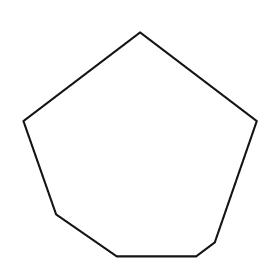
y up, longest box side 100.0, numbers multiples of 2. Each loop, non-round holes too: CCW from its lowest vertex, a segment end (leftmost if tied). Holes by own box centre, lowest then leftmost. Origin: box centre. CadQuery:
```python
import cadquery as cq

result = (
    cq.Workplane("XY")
    .moveTo(-10.0, -48.0)
    .lineTo(24.0, -48.0)
    .lineTo(32.0, -42.0)
    .lineTo(50.0, 10.0)
    .lineTo(0.0, 48.0)
    .lineTo(-50.0, 10.0)
    .lineTo(-36.0, -30.0)
    .close()
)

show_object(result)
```